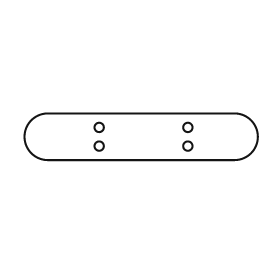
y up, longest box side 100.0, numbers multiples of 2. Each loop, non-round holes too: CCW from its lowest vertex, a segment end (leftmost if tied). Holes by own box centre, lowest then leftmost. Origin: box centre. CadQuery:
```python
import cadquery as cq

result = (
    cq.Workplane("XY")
    .moveTo(-40.0, -10.0)
    .lineTo(40.0, -10.0)
    .threePointArc((50.0, 0.0), (40.0, 10.0))
    .lineTo(-40.0, 10.0)
    .threePointArc((-50.0, 0.0), (-40.0, -10.0))
    .close()
    .moveTo(-18.0, -4.0)
    .circle(2.0)
    .moveTo(20.0, -4.0)
    .circle(2.0)
    .moveTo(-18.0, 4.0)
    .circle(2.0)
    .moveTo(20.0, 4.0)
    .circle(2.0)
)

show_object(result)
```